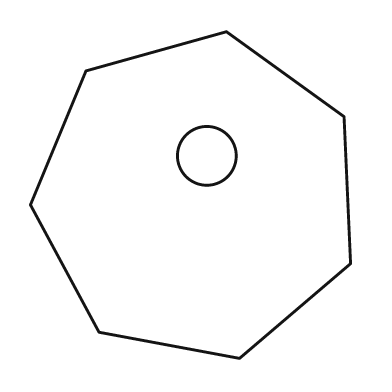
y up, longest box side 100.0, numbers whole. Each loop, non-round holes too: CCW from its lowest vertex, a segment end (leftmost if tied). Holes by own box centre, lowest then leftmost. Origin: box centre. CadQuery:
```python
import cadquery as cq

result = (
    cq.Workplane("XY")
    .moveTo(15.0, -50.0)
    .lineTo(49.0, -21.0)
    .lineTo(47.0, 24.0)
    .lineTo(11.0, 50.0)
    .lineTo(-32.0, 38.0)
    .lineTo(-49.0, -3.0)
    .lineTo(-28.0, -42.0)
    .close()
    .moveTo(5.0, 12.0)
    .circle(9.0)
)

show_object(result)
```